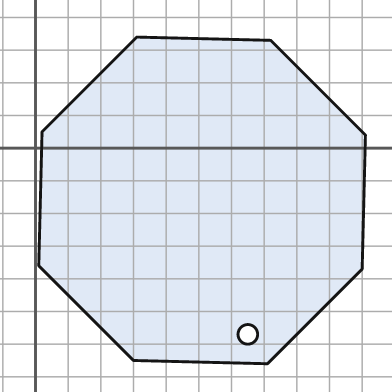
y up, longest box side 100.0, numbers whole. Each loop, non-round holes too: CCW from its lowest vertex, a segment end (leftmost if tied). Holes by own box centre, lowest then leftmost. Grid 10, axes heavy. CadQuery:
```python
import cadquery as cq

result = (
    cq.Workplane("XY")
    .moveTo(71.0, -66.0)
    .lineTo(100.0, -37.0)
    .lineTo(101.0, 4.0)
    .lineTo(72.0, 33.0)
    .lineTo(31.0, 34.0)
    .lineTo(2.0, 5.0)
    .lineTo(1.0, -36.0)
    .lineTo(30.0, -65.0)
    .close()
    .moveTo(65.0, -57.0)
    .circle(3.0)
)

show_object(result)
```